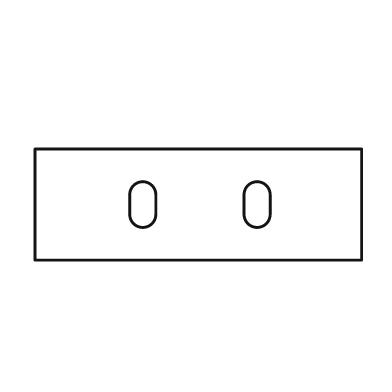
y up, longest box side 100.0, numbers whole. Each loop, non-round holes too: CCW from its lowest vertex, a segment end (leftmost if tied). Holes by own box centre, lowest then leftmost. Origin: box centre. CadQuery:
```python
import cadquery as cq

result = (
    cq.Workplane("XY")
    .moveTo(-50.0, -17.0)
    .lineTo(50.0, -17.0)
    .lineTo(50.0, 17.0)
    .lineTo(-50.0, 17.0)
    .close()
    .moveTo(-21.0, -3.0)
    .threePointArc((-17.0, -7.0), (-13.0, -3.0))
    .lineTo(-13.0, 3.0)
    .threePointArc((-17.0, 7.0), (-21.0, 3.0))
    .close()
    .moveTo(14.0, -3.0)
    .threePointArc((18.0, -7.0), (22.0, -3.0))
    .lineTo(22.0, 3.0)
    .threePointArc((18.0, 7.0), (14.0, 3.0))
    .close()
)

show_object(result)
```